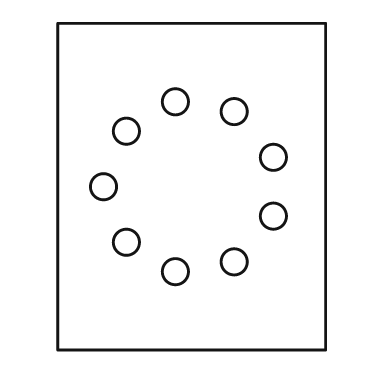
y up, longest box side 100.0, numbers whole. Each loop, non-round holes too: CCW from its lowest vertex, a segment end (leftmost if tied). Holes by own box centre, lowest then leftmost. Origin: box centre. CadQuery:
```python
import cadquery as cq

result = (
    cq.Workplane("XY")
    .moveTo(-41.0, -50.0)
    .lineTo(41.0, -50.0)
    .lineTo(41.0, 50.0)
    .lineTo(-41.0, 50.0)
    .close()
    .moveTo(-5.0, -26.0)
    .circle(4.0)
    .moveTo(13.0, -23.0)
    .circle(4.0)
    .moveTo(-20.0, -17.0)
    .circle(4.0)
    .moveTo(25.0, -9.0)
    .circle(4.0)
    .moveTo(-27.0, 0.0)
    .circle(4.0)
    .moveTo(25.0, 9.0)
    .circle(4.0)
    .moveTo(-20.0, 17.0)
    .circle(4.0)
    .moveTo(13.0, 23.0)
    .circle(4.0)
    .moveTo(-5.0, 26.0)
    .circle(4.0)
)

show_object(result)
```